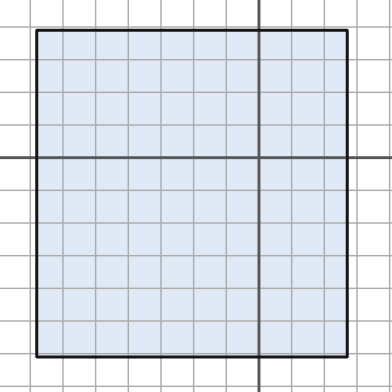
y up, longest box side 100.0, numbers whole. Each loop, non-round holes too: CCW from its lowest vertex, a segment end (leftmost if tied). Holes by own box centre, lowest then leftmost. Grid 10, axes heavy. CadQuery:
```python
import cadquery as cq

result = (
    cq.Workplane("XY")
    .moveTo(-68.0, -61.0)
    .lineTo(27.0, -61.0)
    .lineTo(27.0, 39.0)
    .lineTo(-68.0, 39.0)
    .close()
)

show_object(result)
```